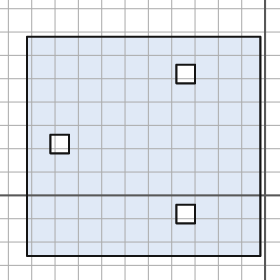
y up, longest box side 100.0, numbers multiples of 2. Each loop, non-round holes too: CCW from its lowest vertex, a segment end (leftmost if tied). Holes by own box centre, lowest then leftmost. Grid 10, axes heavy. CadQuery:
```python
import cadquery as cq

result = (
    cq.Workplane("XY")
    .moveTo(-102.0, -26.0)
    .lineTo(-2.0, -26.0)
    .lineTo(-2.0, 68.0)
    .lineTo(-102.0, 68.0)
    .close()
    .moveTo(-38.0, -12.0)
    .lineTo(-30.0, -12.0)
    .lineTo(-30.0, -4.0)
    .lineTo(-38.0, -4.0)
    .close()
    .moveTo(-92.0, 18.0)
    .lineTo(-84.0, 18.0)
    .lineTo(-84.0, 26.0)
    .lineTo(-92.0, 26.0)
    .close()
    .moveTo(-38.0, 48.0)
    .lineTo(-30.0, 48.0)
    .lineTo(-30.0, 56.0)
    .lineTo(-38.0, 56.0)
    .close()
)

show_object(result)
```